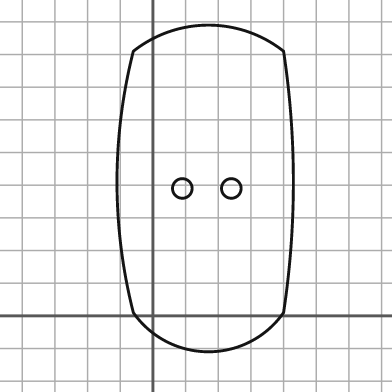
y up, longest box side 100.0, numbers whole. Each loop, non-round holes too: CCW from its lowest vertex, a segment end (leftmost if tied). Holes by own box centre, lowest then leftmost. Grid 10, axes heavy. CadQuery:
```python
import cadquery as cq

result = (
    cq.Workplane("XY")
    .moveTo(-6.0, 1.0)
    .threePointArc((17.0, -11.0), (40.0, 1.0))
    .threePointArc((43.0, 41.0), (40.0, 81.0))
    .threePointArc((17.0, 89.0), (-6.0, 81.0))
    .threePointArc((-11.0, 41.0), (-6.0, 1.0))
    .close()
    .moveTo(9.0, 39.0)
    .circle(3.0)
    .moveTo(24.0, 39.0)
    .circle(3.0)
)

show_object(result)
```